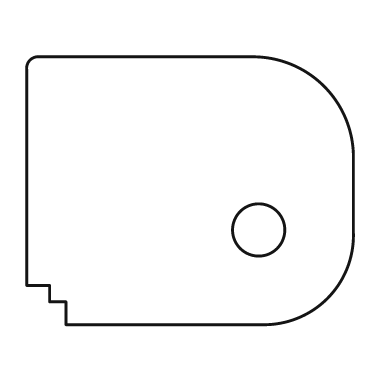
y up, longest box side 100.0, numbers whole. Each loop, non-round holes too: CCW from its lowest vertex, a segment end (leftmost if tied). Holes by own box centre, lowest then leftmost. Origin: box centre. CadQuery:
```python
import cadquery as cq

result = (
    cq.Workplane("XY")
    .moveTo(-38.0, -41.0)
    .lineTo(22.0, -41.0)
    .threePointArc((42.0, -33.0), (50.0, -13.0))
    .lineTo(50.0, 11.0)
    .threePointArc((41.0, 32.0), (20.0, 41.0))
    .lineTo(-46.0, 41.0)
    .threePointArc((-49.0, 40.0), (-50.0, 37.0))
    .lineTo(-50.0, -29.0)
    .lineTo(-43.0, -29.0)
    .lineTo(-43.0, -34.0)
    .lineTo(-38.0, -34.0)
    .close()
    .moveTo(21.0, -12.0)
    .circle(8.0)
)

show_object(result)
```